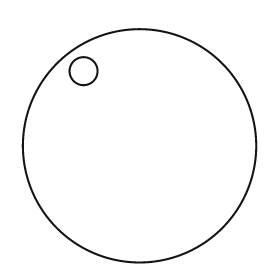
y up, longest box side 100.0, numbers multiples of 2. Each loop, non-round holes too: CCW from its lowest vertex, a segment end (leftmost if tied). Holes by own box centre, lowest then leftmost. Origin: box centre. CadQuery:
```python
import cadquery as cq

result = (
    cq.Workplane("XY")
    .moveTo(0.0, 0.0)
    .circle(50.0)
    .moveTo(-24.0, 32.0)
    .circle(6.0)
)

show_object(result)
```